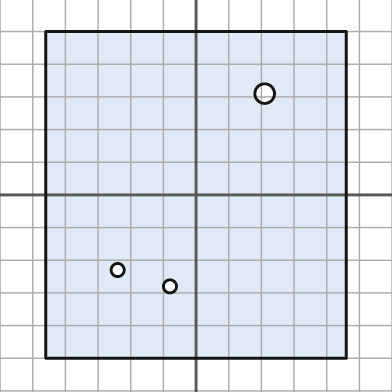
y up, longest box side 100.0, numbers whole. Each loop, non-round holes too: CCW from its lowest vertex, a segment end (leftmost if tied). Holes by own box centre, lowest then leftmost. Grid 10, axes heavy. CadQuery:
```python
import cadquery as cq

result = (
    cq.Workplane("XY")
    .moveTo(-46.0, -50.0)
    .lineTo(46.0, -50.0)
    .lineTo(46.0, 50.0)
    .lineTo(-46.0, 50.0)
    .close()
    .moveTo(-8.0, -28.0)
    .circle(2.0)
    .moveTo(-24.0, -23.0)
    .circle(2.0)
    .moveTo(21.0, 31.0)
    .circle(3.0)
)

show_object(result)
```